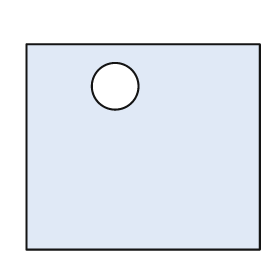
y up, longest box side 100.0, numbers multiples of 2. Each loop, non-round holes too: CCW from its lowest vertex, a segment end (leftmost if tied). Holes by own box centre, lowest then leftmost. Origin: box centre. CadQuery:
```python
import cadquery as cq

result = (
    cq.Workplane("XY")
    .moveTo(-50.0, -44.0)
    .lineTo(50.0, -44.0)
    .lineTo(50.0, 44.0)
    .lineTo(-50.0, 44.0)
    .close()
    .moveTo(-12.0, 26.0)
    .circle(10.0)
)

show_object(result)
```